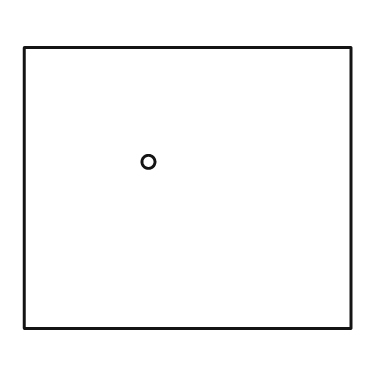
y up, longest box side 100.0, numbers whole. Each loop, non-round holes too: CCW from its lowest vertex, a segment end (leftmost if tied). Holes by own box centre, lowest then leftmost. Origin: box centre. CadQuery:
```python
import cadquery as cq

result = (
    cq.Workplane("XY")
    .moveTo(-50.0, -43.0)
    .lineTo(50.0, -43.0)
    .lineTo(50.0, 43.0)
    .lineTo(-50.0, 43.0)
    .close()
    .moveTo(-12.0, 8.0)
    .circle(2.0)
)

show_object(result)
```